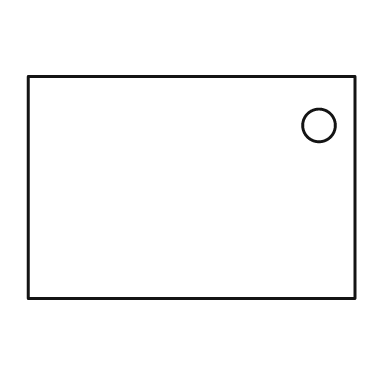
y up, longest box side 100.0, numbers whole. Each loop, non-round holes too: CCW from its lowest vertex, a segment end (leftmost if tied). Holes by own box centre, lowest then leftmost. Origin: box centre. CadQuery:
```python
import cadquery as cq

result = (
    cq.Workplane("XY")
    .moveTo(-50.0, -34.0)
    .lineTo(50.0, -34.0)
    .lineTo(50.0, 34.0)
    .lineTo(-50.0, 34.0)
    .close()
    .moveTo(39.0, 19.0)
    .circle(5.0)
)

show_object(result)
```